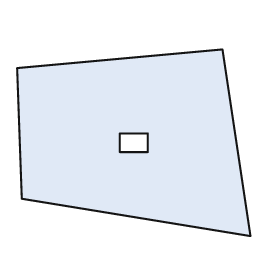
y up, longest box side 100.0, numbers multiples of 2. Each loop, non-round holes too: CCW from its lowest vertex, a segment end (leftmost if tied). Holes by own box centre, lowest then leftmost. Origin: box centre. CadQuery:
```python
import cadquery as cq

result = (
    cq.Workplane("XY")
    .moveTo(50.0, -40.0)
    .lineTo(38.0, 40.0)
    .lineTo(-50.0, 32.0)
    .lineTo(-48.0, -24.0)
    .close()
    .moveTo(-6.0, -4.0)
    .lineTo(6.0, -4.0)
    .lineTo(6.0, 4.0)
    .lineTo(-6.0, 4.0)
    .close()
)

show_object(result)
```